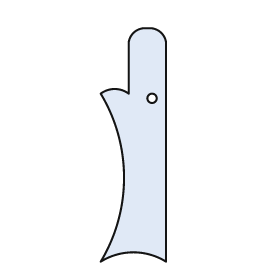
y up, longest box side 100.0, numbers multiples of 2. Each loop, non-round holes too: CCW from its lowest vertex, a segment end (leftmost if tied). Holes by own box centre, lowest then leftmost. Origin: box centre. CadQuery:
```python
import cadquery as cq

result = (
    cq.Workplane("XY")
    .moveTo(-14.0, -50.0)
    .threePointArc((0.0, -46.0), (14.0, -50.0))
    .lineTo(14.0, 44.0)
    .threePointArc((12.0, 48.0), (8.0, 50.0))
    .lineTo(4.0, 50.0)
    .threePointArc((0.0, 48.0), (-2.0, 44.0))
    .lineTo(-2.0, 22.0)
    .threePointArc((-8.0, 24.0), (-14.0, 22.0))
    .threePointArc((-4.0, -14.0), (-14.0, -50.0))
    .close()
    .moveTo(8.0, 20.0)
    .circle(2.0)
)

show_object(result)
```